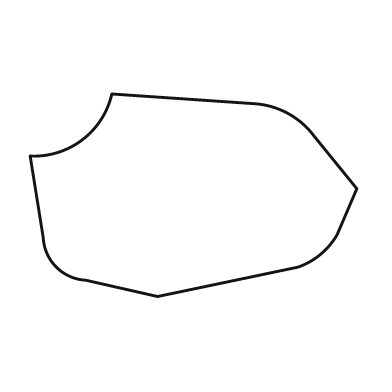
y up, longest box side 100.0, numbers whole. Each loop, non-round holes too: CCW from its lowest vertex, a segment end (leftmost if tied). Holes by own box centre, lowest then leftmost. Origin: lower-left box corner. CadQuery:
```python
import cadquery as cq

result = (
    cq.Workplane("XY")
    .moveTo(39.0, 0.0)
    .lineTo(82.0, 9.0)
    .threePointArc((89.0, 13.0), (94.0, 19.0))
    .lineTo(100.0, 33.0)
    .lineTo(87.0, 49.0)
    .threePointArc((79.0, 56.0), (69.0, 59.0))
    .lineTo(25.0, 62.0)
    .threePointArc((16.0, 48.0), (0.0, 43.0))
    .lineTo(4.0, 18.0)
    .threePointArc((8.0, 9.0), (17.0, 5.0))
    .close()
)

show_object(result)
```